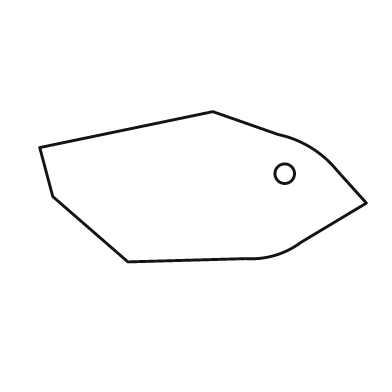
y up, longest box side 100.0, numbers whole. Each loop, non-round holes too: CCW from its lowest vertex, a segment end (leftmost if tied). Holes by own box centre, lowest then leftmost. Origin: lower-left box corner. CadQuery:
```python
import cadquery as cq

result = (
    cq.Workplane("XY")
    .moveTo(27.0, 0.0)
    .lineTo(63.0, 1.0)
    .threePointArc((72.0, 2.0), (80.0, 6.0))
    .lineTo(100.0, 18.0)
    .lineTo(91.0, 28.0)
    .threePointArc((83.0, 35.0), (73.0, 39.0))
    .lineTo(53.0, 46.0)
    .lineTo(0.0, 35.0)
    .lineTo(4.0, 20.0)
    .close()
    .moveTo(75.0, 27.0)
    .circle(3.0)
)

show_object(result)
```